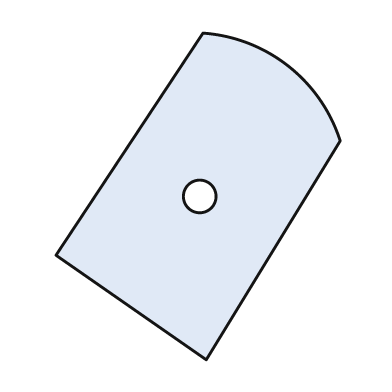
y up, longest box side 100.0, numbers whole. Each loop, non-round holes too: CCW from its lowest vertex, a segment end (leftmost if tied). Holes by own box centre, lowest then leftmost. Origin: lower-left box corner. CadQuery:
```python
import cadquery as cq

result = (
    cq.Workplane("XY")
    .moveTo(46.0, 0.0)
    .lineTo(87.0, 67.0)
    .threePointArc((71.0, 90.0), (45.0, 100.0))
    .lineTo(0.0, 32.0)
    .close()
    .moveTo(44.0, 50.0)
    .circle(5.0)
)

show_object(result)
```